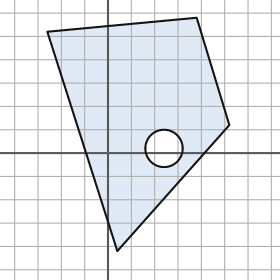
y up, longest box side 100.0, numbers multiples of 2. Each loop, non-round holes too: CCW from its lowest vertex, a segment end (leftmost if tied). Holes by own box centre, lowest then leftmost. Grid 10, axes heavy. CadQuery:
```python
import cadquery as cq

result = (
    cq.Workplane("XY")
    .moveTo(4.0, -42.0)
    .lineTo(52.0, 12.0)
    .lineTo(38.0, 58.0)
    .lineTo(-26.0, 52.0)
    .close()
    .moveTo(24.0, 2.0)
    .circle(8.0)
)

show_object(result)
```